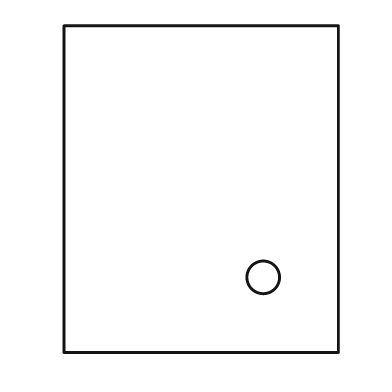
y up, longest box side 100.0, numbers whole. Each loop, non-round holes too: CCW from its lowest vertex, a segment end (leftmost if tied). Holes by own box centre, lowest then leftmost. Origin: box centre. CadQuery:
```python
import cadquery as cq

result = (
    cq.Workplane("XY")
    .moveTo(-42.0, -50.0)
    .lineTo(42.0, -50.0)
    .lineTo(42.0, 50.0)
    .lineTo(-42.0, 50.0)
    .close()
    .moveTo(19.0, -27.0)
    .circle(5.0)
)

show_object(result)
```